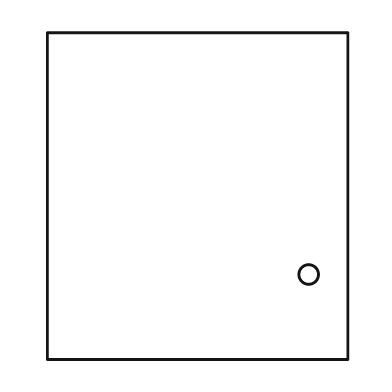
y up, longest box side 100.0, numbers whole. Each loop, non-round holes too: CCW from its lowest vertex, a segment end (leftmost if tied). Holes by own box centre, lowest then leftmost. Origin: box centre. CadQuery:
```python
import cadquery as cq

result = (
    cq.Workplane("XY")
    .moveTo(-46.0, -50.0)
    .lineTo(46.0, -50.0)
    .lineTo(46.0, 50.0)
    .lineTo(-46.0, 50.0)
    .close()
    .moveTo(34.0, -24.0)
    .circle(3.0)
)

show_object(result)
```